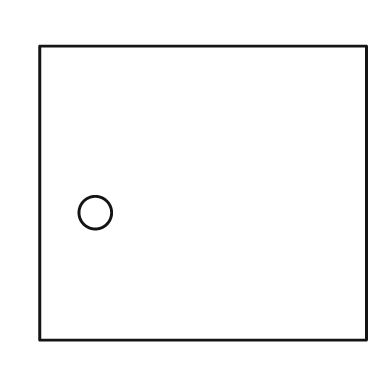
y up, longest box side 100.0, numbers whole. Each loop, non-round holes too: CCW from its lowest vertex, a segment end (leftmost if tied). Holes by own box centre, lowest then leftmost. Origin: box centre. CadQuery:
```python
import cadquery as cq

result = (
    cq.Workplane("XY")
    .moveTo(-50.0, -45.0)
    .lineTo(50.0, -45.0)
    .lineTo(50.0, 45.0)
    .lineTo(-50.0, 45.0)
    .close()
    .moveTo(-33.0, -6.0)
    .circle(5.0)
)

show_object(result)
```